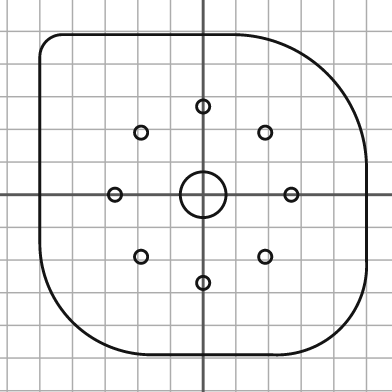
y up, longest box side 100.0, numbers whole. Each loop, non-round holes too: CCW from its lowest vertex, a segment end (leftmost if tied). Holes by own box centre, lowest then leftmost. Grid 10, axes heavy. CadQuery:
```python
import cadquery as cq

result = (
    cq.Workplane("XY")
    .moveTo(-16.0, -49.0)
    .lineTo(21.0, -49.0)
    .threePointArc((42.0, -41.0), (50.0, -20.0))
    .lineTo(50.0, 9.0)
    .threePointArc((38.0, 37.0), (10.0, 49.0))
    .lineTo(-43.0, 49.0)
    .threePointArc((-48.0, 47.0), (-50.0, 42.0))
    .lineTo(-50.0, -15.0)
    .threePointArc((-40.0, -39.0), (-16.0, -49.0))
    .close()
    .moveTo(0.0, -27.0)
    .circle(2.0)
    .moveTo(-19.0, -19.0)
    .circle(2.0)
    .moveTo(19.0, -19.0)
    .circle(2.0)
    .moveTo(-27.0, 0.0)
    .circle(2.0)
    .moveTo(0.0, 0.0)
    .circle(7.0)
    .moveTo(27.0, 0.0)
    .circle(2.0)
    .moveTo(-19.0, 19.0)
    .circle(2.0)
    .moveTo(19.0, 19.0)
    .circle(2.0)
    .moveTo(0.0, 27.0)
    .circle(2.0)
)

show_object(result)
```